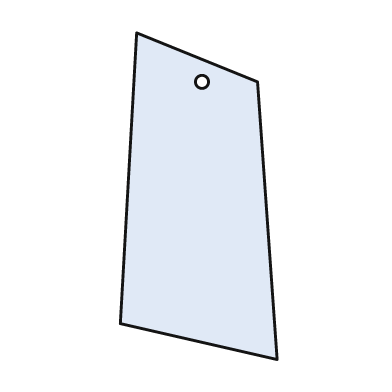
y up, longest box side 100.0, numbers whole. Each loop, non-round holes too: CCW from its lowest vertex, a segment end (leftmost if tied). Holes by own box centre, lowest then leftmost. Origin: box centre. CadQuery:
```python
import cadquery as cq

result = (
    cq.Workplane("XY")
    .moveTo(24.0, -50.0)
    .lineTo(18.0, 35.0)
    .lineTo(-19.0, 50.0)
    .lineTo(-24.0, -39.0)
    .close()
    .moveTo(1.0, 35.0)
    .circle(2.0)
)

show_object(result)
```